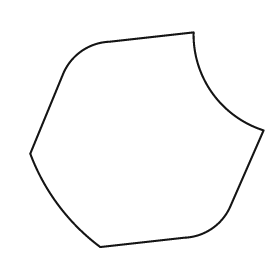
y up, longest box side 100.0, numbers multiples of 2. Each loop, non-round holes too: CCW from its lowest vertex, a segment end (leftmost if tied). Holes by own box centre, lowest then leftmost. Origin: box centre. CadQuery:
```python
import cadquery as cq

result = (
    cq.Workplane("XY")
    .moveTo(-20.0, -46.0)
    .lineTo(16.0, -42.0)
    .threePointArc((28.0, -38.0), (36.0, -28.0))
    .lineTo(50.0, 4.0)
    .threePointArc((28.0, 20.0), (20.0, 46.0))
    .lineTo(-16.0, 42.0)
    .threePointArc((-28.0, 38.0), (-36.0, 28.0))
    .lineTo(-50.0, -6.0)
    .threePointArc((-38.0, -28.0), (-20.0, -46.0))
    .close()
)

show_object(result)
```